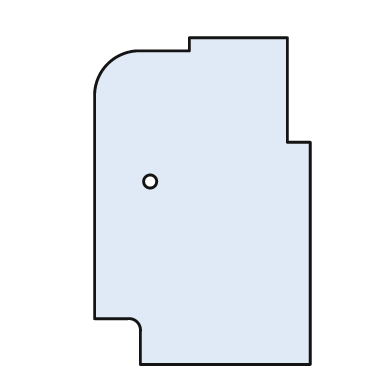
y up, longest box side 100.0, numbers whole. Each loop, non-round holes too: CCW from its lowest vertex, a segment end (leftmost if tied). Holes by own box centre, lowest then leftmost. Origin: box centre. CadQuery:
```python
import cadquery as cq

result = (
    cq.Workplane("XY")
    .moveTo(-19.0, -50.0)
    .lineTo(33.0, -50.0)
    .lineTo(33.0, 18.0)
    .lineTo(26.0, 18.0)
    .lineTo(26.0, 50.0)
    .lineTo(-4.0, 50.0)
    .lineTo(-4.0, 46.0)
    .lineTo(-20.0, 46.0)
    .threePointArc((-29.0, 42.0), (-33.0, 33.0))
    .lineTo(-33.0, -36.0)
    .lineTo(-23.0, -36.0)
    .threePointArc((-20.0, -37.0), (-19.0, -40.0))
    .close()
    .moveTo(-16.0, 6.0)
    .circle(2.0)
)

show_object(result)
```